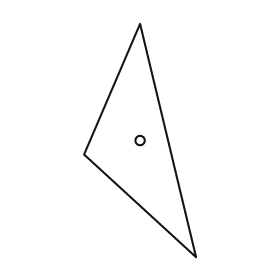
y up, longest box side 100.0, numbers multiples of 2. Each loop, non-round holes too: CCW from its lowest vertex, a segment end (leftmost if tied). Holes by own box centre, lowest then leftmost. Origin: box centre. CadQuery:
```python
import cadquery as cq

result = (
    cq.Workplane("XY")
    .moveTo(24.0, -50.0)
    .lineTo(0.0, 50.0)
    .lineTo(-24.0, -6.0)
    .close()
    .moveTo(0.0, 0.0)
    .circle(2.0)
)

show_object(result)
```